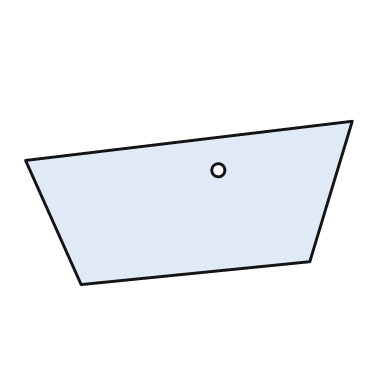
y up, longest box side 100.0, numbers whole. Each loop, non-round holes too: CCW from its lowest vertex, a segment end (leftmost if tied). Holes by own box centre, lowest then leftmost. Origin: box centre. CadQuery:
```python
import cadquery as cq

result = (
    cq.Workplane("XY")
    .moveTo(-33.0, -25.0)
    .lineTo(37.0, -18.0)
    .lineTo(50.0, 25.0)
    .lineTo(-50.0, 13.0)
    .close()
    .moveTo(9.0, 10.0)
    .circle(2.0)
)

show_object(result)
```